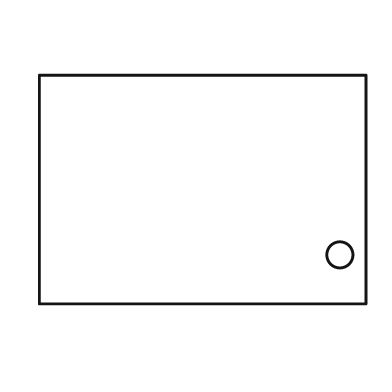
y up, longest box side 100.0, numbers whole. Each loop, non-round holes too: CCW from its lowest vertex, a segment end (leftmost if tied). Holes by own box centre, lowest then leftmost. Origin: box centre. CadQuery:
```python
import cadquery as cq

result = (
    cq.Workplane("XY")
    .moveTo(-50.0, -35.0)
    .lineTo(50.0, -35.0)
    .lineTo(50.0, 35.0)
    .lineTo(-50.0, 35.0)
    .close()
    .moveTo(42.0, -20.0)
    .circle(4.0)
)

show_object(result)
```